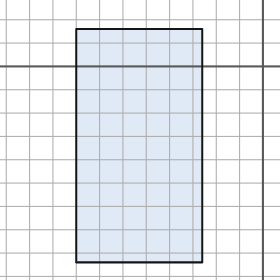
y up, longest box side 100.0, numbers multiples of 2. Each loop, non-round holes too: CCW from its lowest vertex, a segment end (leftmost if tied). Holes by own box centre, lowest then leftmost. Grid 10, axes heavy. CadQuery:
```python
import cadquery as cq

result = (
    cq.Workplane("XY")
    .moveTo(-80.0, -84.0)
    .lineTo(-26.0, -84.0)
    .lineTo(-26.0, 16.0)
    .lineTo(-80.0, 16.0)
    .close()
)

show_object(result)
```